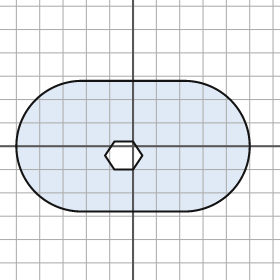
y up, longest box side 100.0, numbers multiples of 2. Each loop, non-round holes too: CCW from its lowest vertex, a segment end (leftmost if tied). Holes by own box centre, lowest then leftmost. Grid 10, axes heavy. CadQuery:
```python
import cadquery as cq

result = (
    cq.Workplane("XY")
    .moveTo(-22.0, -28.0)
    .lineTo(22.0, -28.0)
    .threePointArc((50.0, 0.0), (22.0, 28.0))
    .lineTo(-22.0, 28.0)
    .threePointArc((-50.0, 0.0), (-22.0, -28.0))
    .close()
    .moveTo(-8.0, -10.0)
    .lineTo(0.0, -10.0)
    .lineTo(4.0, -4.0)
    .lineTo(0.0, 2.0)
    .lineTo(-8.0, 2.0)
    .lineTo(-12.0, -4.0)
    .close()
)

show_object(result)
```